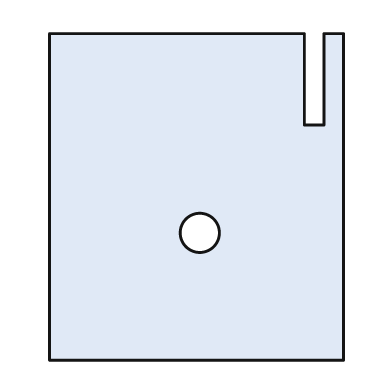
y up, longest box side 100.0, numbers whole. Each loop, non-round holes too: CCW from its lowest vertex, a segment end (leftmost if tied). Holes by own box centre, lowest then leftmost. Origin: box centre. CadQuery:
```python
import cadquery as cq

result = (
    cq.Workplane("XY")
    .moveTo(-45.0, -50.0)
    .lineTo(45.0, -50.0)
    .lineTo(45.0, 50.0)
    .lineTo(39.0, 50.0)
    .lineTo(39.0, 22.0)
    .lineTo(33.0, 22.0)
    .lineTo(33.0, 50.0)
    .lineTo(-45.0, 50.0)
    .close()
    .moveTo(1.0, -11.0)
    .circle(6.0)
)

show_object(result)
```